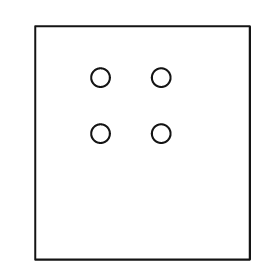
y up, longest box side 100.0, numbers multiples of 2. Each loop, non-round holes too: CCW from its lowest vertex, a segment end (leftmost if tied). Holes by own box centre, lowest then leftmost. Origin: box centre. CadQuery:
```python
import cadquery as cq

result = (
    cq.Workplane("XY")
    .moveTo(-46.0, -50.0)
    .lineTo(46.0, -50.0)
    .lineTo(46.0, 50.0)
    .lineTo(-46.0, 50.0)
    .close()
    .moveTo(-18.0, 4.0)
    .circle(4.0)
    .moveTo(8.0, 4.0)
    .circle(4.0)
    .moveTo(-18.0, 28.0)
    .circle(4.0)
    .moveTo(8.0, 28.0)
    .circle(4.0)
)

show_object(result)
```